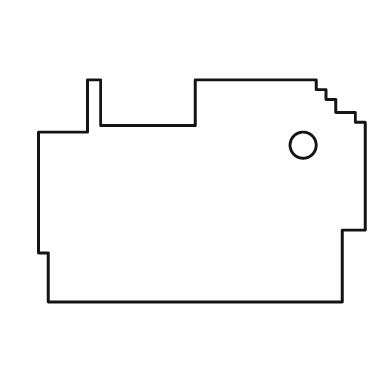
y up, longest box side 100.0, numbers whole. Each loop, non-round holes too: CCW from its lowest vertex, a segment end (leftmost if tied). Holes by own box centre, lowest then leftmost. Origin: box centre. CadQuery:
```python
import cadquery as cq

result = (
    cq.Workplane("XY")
    .moveTo(-47.0, -34.0)
    .lineTo(43.0, -34.0)
    .lineTo(43.0, -12.0)
    .lineTo(50.0, -12.0)
    .lineTo(50.0, 21.0)
    .lineTo(47.0, 21.0)
    .lineTo(47.0, 24.0)
    .lineTo(41.0, 24.0)
    .lineTo(41.0, 28.0)
    .lineTo(38.0, 28.0)
    .lineTo(38.0, 31.0)
    .lineTo(35.0, 31.0)
    .lineTo(35.0, 34.0)
    .lineTo(-2.0, 34.0)
    .lineTo(-2.0, 20.0)
    .lineTo(-31.0, 20.0)
    .lineTo(-31.0, 34.0)
    .lineTo(-35.0, 34.0)
    .lineTo(-35.0, 18.0)
    .lineTo(-50.0, 18.0)
    .lineTo(-50.0, -19.0)
    .lineTo(-47.0, -19.0)
    .close()
    .moveTo(31.0, 14.0)
    .circle(4.0)
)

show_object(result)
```